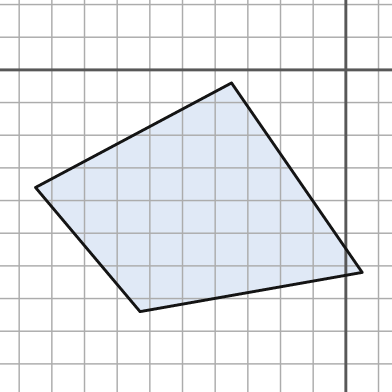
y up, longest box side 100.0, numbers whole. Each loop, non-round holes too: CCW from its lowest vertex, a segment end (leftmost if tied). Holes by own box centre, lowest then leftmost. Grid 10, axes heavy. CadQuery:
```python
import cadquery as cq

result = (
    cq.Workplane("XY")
    .moveTo(-63.0, -74.0)
    .lineTo(5.0, -62.0)
    .lineTo(-35.0, -4.0)
    .lineTo(-95.0, -36.0)
    .close()
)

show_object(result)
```